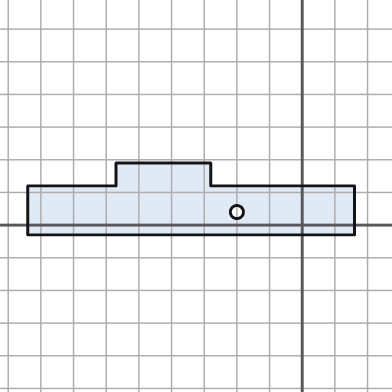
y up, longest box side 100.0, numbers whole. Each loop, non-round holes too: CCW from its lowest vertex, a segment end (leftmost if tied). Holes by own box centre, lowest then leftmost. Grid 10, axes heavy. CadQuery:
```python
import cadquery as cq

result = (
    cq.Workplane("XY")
    .moveTo(-84.0, -3.0)
    .lineTo(16.0, -3.0)
    .lineTo(16.0, 12.0)
    .lineTo(-28.0, 12.0)
    .lineTo(-28.0, 19.0)
    .lineTo(-57.0, 19.0)
    .lineTo(-57.0, 12.0)
    .lineTo(-84.0, 12.0)
    .close()
    .moveTo(-20.0, 4.0)
    .circle(2.0)
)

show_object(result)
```